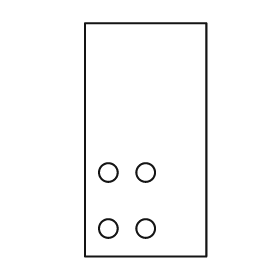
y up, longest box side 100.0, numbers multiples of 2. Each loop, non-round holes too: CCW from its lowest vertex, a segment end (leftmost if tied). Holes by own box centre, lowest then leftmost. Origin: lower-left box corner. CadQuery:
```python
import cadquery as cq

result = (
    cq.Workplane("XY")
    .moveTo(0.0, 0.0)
    .lineTo(52.0, 0.0)
    .lineTo(52.0, 100.0)
    .lineTo(0.0, 100.0)
    .close()
    .moveTo(10.0, 12.0)
    .circle(4.0)
    .moveTo(26.0, 12.0)
    .circle(4.0)
    .moveTo(10.0, 36.0)
    .circle(4.0)
    .moveTo(26.0, 36.0)
    .circle(4.0)
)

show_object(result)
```